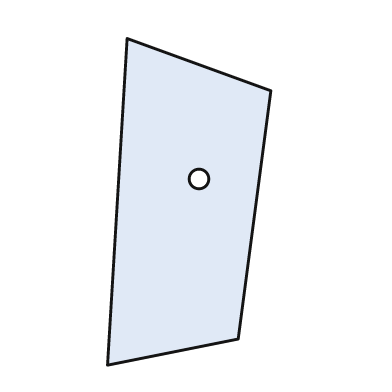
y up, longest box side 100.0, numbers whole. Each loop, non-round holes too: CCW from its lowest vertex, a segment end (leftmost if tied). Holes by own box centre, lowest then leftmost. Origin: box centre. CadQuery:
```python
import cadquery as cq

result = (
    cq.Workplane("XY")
    .moveTo(-25.0, -50.0)
    .lineTo(15.0, -42.0)
    .lineTo(25.0, 34.0)
    .lineTo(-19.0, 50.0)
    .close()
    .moveTo(3.0, 7.0)
    .circle(3.0)
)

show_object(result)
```